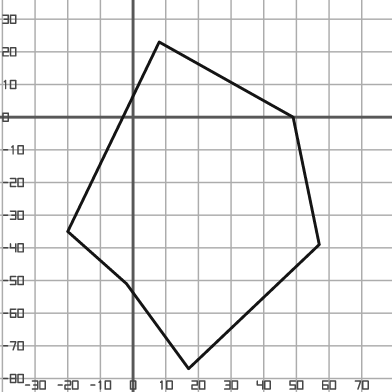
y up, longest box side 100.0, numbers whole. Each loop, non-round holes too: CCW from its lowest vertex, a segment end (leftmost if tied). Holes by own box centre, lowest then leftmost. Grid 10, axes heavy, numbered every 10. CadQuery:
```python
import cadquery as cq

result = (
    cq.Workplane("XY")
    .moveTo(17.0, -77.0)
    .lineTo(57.0, -39.0)
    .lineTo(49.0, 0.0)
    .lineTo(8.0, 23.0)
    .lineTo(-20.0, -35.0)
    .lineTo(-2.0, -51.0)
    .close()
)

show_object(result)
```